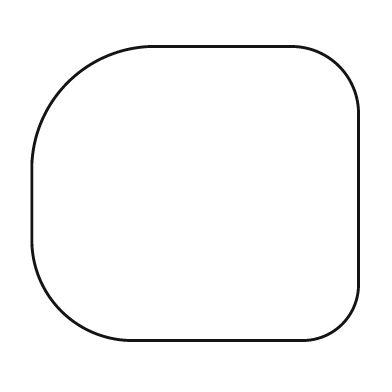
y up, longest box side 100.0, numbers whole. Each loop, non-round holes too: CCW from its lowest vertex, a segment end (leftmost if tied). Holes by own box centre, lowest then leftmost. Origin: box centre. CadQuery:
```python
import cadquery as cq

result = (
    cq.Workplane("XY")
    .moveTo(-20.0, -45.0)
    .lineTo(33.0, -45.0)
    .threePointArc((45.0, -40.0), (50.0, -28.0))
    .lineTo(50.0, 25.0)
    .threePointArc((44.0, 39.0), (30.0, 45.0))
    .lineTo(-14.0, 45.0)
    .threePointArc((-39.0, 34.0), (-50.0, 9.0))
    .lineTo(-50.0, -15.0)
    .threePointArc((-41.0, -36.0), (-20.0, -45.0))
    .close()
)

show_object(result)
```